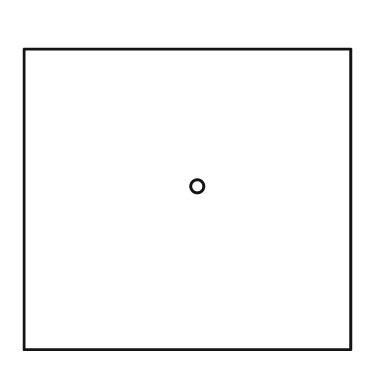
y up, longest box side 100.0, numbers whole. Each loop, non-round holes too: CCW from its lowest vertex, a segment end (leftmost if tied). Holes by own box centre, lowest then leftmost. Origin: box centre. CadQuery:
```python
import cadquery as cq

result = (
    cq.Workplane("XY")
    .moveTo(-50.0, -46.0)
    .lineTo(50.0, -46.0)
    .lineTo(50.0, 46.0)
    .lineTo(-50.0, 46.0)
    .close()
    .moveTo(3.0, 4.0)
    .circle(2.0)
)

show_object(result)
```